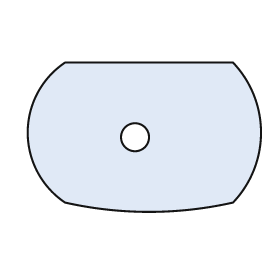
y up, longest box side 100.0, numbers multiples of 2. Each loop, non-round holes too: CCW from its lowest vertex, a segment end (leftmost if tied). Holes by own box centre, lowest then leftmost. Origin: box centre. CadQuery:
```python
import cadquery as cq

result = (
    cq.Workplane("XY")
    .moveTo(-34.0, -28.0)
    .threePointArc((2.0, -32.0), (38.0, -28.0))
    .threePointArc((50.0, 2.0), (38.0, 32.0))
    .lineTo(-34.0, 32.0)
    .threePointArc((-50.0, 2.0), (-34.0, -28.0))
    .close()
    .moveTo(-4.0, 0.0)
    .circle(6.0)
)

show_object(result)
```